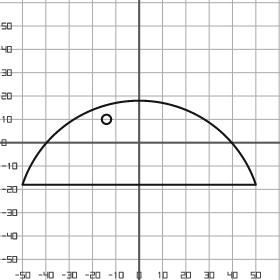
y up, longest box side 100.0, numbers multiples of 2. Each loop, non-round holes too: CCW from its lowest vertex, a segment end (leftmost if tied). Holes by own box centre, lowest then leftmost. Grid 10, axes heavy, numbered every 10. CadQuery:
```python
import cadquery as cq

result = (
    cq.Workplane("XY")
    .moveTo(-50.0, -18.0)
    .lineTo(50.0, -18.0)
    .threePointArc((0.0, 18.0), (-50.0, -18.0))
    .close()
    .moveTo(-14.0, 10.0)
    .circle(2.0)
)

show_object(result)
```